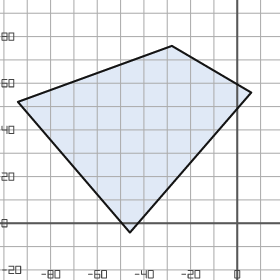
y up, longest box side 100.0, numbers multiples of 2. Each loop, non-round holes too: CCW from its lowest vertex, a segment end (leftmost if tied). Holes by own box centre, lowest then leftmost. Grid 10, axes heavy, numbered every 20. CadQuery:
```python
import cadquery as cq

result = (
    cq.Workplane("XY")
    .moveTo(-46.0, -4.0)
    .lineTo(6.0, 56.0)
    .lineTo(-28.0, 76.0)
    .lineTo(-94.0, 52.0)
    .close()
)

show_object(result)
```